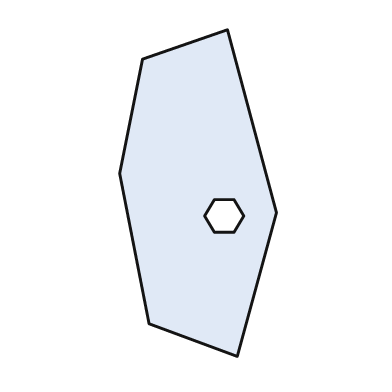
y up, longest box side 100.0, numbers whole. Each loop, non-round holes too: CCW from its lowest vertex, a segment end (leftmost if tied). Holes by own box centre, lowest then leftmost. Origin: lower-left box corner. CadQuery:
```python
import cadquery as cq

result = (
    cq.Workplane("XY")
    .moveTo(36.0, 0.0)
    .lineTo(48.0, 44.0)
    .lineTo(33.0, 100.0)
    .lineTo(7.0, 91.0)
    .lineTo(0.0, 56.0)
    .lineTo(9.0, 10.0)
    .close()
    .moveTo(29.0, 38.0)
    .lineTo(35.0, 38.0)
    .lineTo(38.0, 43.0)
    .lineTo(35.0, 48.0)
    .lineTo(29.0, 48.0)
    .lineTo(26.0, 43.0)
    .close()
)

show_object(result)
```